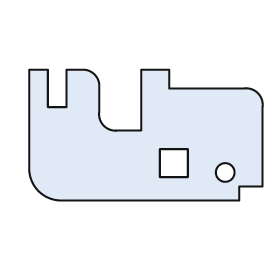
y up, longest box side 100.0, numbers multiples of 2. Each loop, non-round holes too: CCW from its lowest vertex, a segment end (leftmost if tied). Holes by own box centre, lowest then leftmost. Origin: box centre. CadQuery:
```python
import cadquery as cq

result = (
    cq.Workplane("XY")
    .moveTo(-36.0, -28.0)
    .lineTo(40.0, -28.0)
    .lineTo(40.0, -22.0)
    .lineTo(50.0, -22.0)
    .lineTo(50.0, 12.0)
    .threePointArc((48.0, 18.0), (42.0, 20.0))
    .lineTo(10.0, 20.0)
    .lineTo(10.0, 28.0)
    .lineTo(-2.0, 28.0)
    .lineTo(-2.0, 2.0)
    .lineTo(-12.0, 2.0)
    .threePointArc((-18.0, 4.0), (-20.0, 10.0))
    .lineTo(-20.0, 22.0)
    .threePointArc((-22.0, 26.0), (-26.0, 28.0))
    .lineTo(-34.0, 28.0)
    .lineTo(-34.0, 12.0)
    .lineTo(-42.0, 12.0)
    .lineTo(-42.0, 28.0)
    .lineTo(-50.0, 28.0)
    .lineTo(-50.0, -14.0)
    .threePointArc((-46.0, -24.0), (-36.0, -28.0))
    .close()
    .moveTo(34.0, -16.0)
    .circle(4.0)
    .moveTo(6.0, -18.0)
    .lineTo(18.0, -18.0)
    .lineTo(18.0, -6.0)
    .lineTo(6.0, -6.0)
    .close()
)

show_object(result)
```